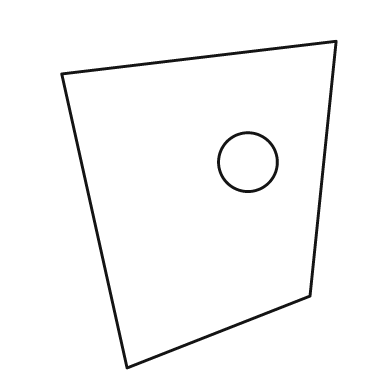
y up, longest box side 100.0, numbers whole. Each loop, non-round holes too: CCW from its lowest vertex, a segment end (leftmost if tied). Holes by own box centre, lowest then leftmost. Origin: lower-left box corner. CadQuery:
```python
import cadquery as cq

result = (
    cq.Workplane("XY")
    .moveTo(20.0, 0.0)
    .lineTo(76.0, 22.0)
    .lineTo(84.0, 100.0)
    .lineTo(0.0, 90.0)
    .close()
    .moveTo(57.0, 63.0)
    .circle(9.0)
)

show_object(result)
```